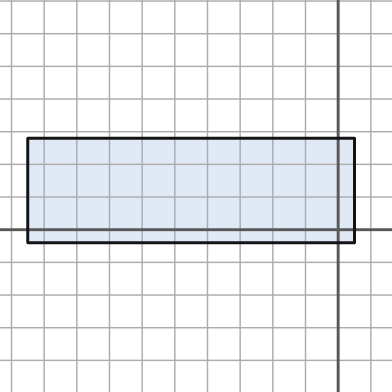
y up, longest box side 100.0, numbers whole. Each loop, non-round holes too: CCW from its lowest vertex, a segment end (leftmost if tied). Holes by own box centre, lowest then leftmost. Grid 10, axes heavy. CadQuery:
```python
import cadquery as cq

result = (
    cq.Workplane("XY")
    .moveTo(-95.0, -4.0)
    .lineTo(5.0, -4.0)
    .lineTo(5.0, 28.0)
    .lineTo(-95.0, 28.0)
    .close()
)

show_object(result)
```